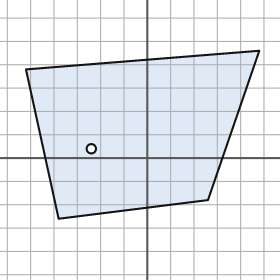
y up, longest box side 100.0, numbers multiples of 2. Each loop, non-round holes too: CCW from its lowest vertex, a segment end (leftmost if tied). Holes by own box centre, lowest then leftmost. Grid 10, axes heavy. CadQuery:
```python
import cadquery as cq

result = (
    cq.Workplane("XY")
    .moveTo(-38.0, -26.0)
    .lineTo(26.0, -18.0)
    .lineTo(48.0, 46.0)
    .lineTo(-52.0, 38.0)
    .close()
    .moveTo(-24.0, 4.0)
    .circle(2.0)
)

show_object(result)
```